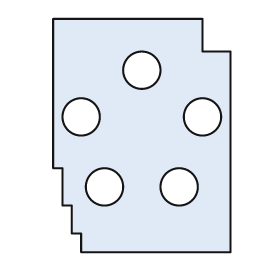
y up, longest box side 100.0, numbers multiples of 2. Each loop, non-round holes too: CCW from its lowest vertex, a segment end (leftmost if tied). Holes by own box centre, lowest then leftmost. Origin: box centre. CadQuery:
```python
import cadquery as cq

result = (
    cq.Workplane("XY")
    .moveTo(-26.0, -50.0)
    .lineTo(38.0, -50.0)
    .lineTo(38.0, 36.0)
    .lineTo(26.0, 36.0)
    .lineTo(26.0, 50.0)
    .lineTo(-38.0, 50.0)
    .lineTo(-38.0, -14.0)
    .lineTo(-34.0, -14.0)
    .lineTo(-34.0, -30.0)
    .lineTo(-30.0, -30.0)
    .lineTo(-30.0, -42.0)
    .lineTo(-26.0, -42.0)
    .close()
    .moveTo(-16.0, -22.0)
    .circle(8.0)
    .moveTo(16.0, -22.0)
    .circle(8.0)
    .moveTo(-26.0, 8.0)
    .circle(8.0)
    .moveTo(26.0, 8.0)
    .circle(8.0)
    .moveTo(0.0, 28.0)
    .circle(8.0)
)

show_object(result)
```